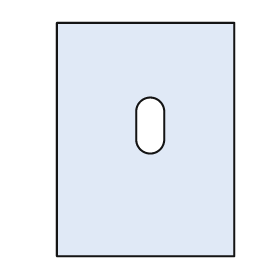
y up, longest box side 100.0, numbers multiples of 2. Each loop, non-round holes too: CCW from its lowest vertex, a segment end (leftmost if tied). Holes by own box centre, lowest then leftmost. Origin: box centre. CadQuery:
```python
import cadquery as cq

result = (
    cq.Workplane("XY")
    .moveTo(-38.0, -50.0)
    .lineTo(38.0, -50.0)
    .lineTo(38.0, 50.0)
    .lineTo(-38.0, 50.0)
    .close()
    .moveTo(-4.0, 0.0)
    .threePointArc((2.0, -6.0), (8.0, 0.0))
    .lineTo(8.0, 12.0)
    .threePointArc((2.0, 18.0), (-4.0, 12.0))
    .close()
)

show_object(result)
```